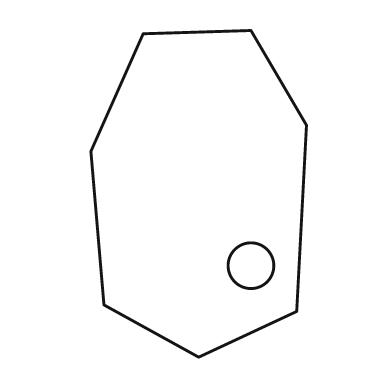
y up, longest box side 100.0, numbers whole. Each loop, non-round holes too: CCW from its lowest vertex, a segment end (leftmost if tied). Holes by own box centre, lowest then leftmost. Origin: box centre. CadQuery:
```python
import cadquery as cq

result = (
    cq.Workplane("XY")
    .moveTo(0.0, -50.0)
    .lineTo(30.0, -36.0)
    .lineTo(33.0, 21.0)
    .lineTo(16.0, 50.0)
    .lineTo(-17.0, 49.0)
    .lineTo(-33.0, 13.0)
    .lineTo(-29.0, -34.0)
    .close()
    .moveTo(16.0, -22.0)
    .circle(7.0)
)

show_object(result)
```